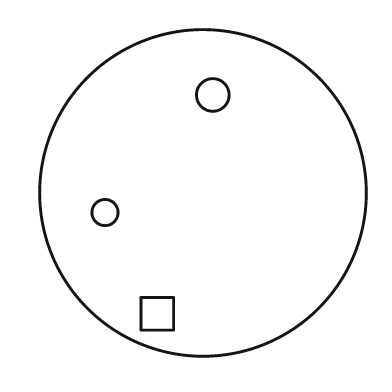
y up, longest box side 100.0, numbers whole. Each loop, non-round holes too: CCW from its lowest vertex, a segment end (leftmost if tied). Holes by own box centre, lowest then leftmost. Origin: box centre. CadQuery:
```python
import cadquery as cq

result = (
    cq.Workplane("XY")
    .moveTo(0.0, 0.0)
    .circle(50.0)
    .moveTo(-19.0, -42.0)
    .lineTo(-9.0, -42.0)
    .lineTo(-9.0, -32.0)
    .lineTo(-19.0, -32.0)
    .close()
    .moveTo(-30.0, -6.0)
    .circle(4.0)
    .moveTo(3.0, 30.0)
    .circle(5.0)
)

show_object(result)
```